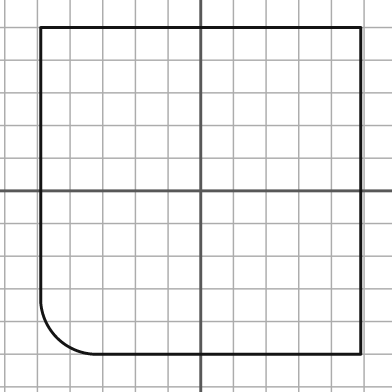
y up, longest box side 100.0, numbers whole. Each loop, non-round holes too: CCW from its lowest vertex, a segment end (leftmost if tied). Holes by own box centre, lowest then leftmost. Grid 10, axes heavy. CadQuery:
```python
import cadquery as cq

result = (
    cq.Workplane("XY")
    .moveTo(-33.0, -50.0)
    .lineTo(49.0, -50.0)
    .lineTo(49.0, 50.0)
    .lineTo(-49.0, 50.0)
    .lineTo(-49.0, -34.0)
    .threePointArc((-44.0, -45.0), (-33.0, -50.0))
    .close()
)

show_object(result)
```